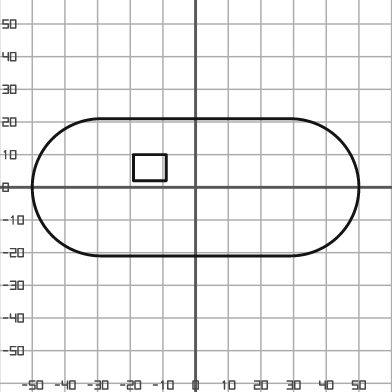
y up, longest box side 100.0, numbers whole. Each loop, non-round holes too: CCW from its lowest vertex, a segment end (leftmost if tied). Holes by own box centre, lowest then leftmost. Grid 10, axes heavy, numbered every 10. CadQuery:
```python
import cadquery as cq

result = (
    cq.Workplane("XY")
    .moveTo(-29.0, -21.0)
    .lineTo(29.0, -21.0)
    .threePointArc((50.0, 0.0), (29.0, 21.0))
    .lineTo(-29.0, 21.0)
    .threePointArc((-50.0, 0.0), (-29.0, -21.0))
    .close()
    .moveTo(-19.0, 2.0)
    .lineTo(-9.0, 2.0)
    .lineTo(-9.0, 10.0)
    .lineTo(-19.0, 10.0)
    .close()
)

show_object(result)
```